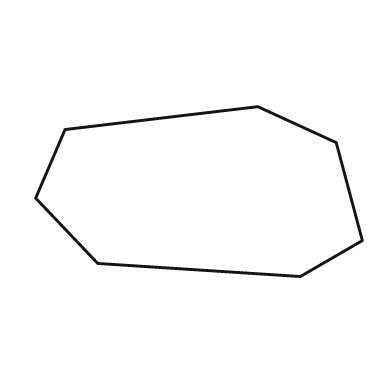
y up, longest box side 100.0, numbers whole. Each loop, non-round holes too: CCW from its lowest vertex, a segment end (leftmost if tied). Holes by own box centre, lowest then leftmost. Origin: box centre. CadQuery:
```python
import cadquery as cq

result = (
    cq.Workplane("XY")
    .moveTo(31.0, -26.0)
    .lineTo(50.0, -15.0)
    .lineTo(42.0, 15.0)
    .lineTo(18.0, 26.0)
    .lineTo(-41.0, 19.0)
    .lineTo(-50.0, -2.0)
    .lineTo(-31.0, -22.0)
    .close()
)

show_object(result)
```